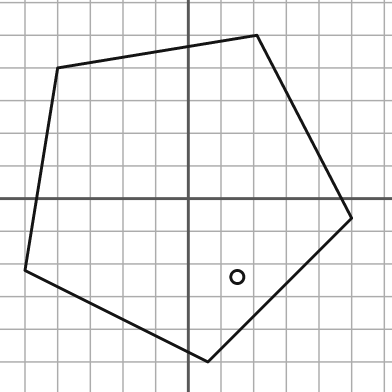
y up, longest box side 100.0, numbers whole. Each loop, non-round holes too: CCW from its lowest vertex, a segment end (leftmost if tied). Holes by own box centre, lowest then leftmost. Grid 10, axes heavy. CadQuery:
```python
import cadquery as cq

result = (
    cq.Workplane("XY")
    .moveTo(6.0, -50.0)
    .lineTo(50.0, -6.0)
    .lineTo(21.0, 50.0)
    .lineTo(-40.0, 40.0)
    .lineTo(-50.0, -22.0)
    .close()
    .moveTo(15.0, -24.0)
    .circle(2.0)
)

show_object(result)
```